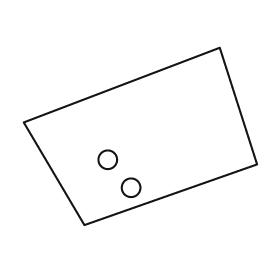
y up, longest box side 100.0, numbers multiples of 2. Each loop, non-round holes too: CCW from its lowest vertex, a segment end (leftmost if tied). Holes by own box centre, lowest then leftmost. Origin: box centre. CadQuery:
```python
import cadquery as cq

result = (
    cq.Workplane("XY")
    .moveTo(-24.0, -38.0)
    .lineTo(50.0, -12.0)
    .lineTo(34.0, 38.0)
    .lineTo(-50.0, 6.0)
    .close()
    .moveTo(-4.0, -22.0)
    .circle(4.0)
    .moveTo(-14.0, -10.0)
    .circle(4.0)
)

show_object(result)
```